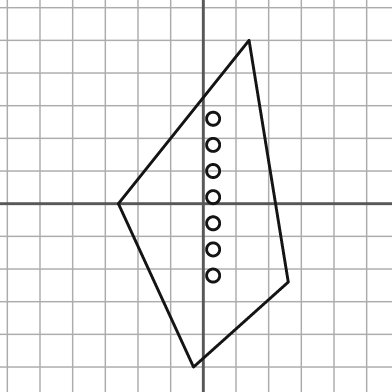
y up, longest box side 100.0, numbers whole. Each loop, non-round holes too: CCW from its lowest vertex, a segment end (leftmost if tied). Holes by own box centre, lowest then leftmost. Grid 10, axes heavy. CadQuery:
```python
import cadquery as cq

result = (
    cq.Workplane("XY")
    .moveTo(-3.0, -50.0)
    .lineTo(26.0, -24.0)
    .lineTo(14.0, 50.0)
    .lineTo(-26.0, 0.0)
    .close()
    .moveTo(3.0, -22.0)
    .circle(2.0)
    .moveTo(3.0, -14.0)
    .circle(2.0)
    .moveTo(3.0, -6.0)
    .circle(2.0)
    .moveTo(3.0, 2.0)
    .circle(2.0)
    .moveTo(3.0, 10.0)
    .circle(2.0)
    .moveTo(3.0, 18.0)
    .circle(2.0)
    .moveTo(3.0, 26.0)
    .circle(2.0)
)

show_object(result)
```